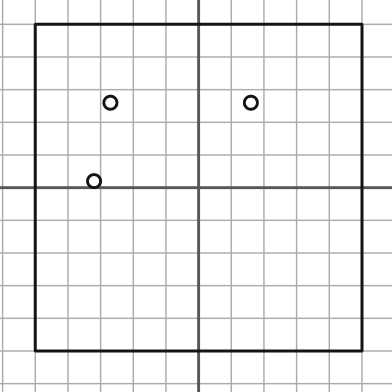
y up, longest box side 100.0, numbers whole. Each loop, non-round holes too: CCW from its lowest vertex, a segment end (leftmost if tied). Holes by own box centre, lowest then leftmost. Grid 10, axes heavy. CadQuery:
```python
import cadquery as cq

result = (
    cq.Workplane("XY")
    .moveTo(-50.0, -50.0)
    .lineTo(50.0, -50.0)
    .lineTo(50.0, 50.0)
    .lineTo(-50.0, 50.0)
    .close()
    .moveTo(-32.0, 2.0)
    .circle(2.0)
    .moveTo(-27.0, 26.0)
    .circle(2.0)
    .moveTo(16.0, 26.0)
    .circle(2.0)
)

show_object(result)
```